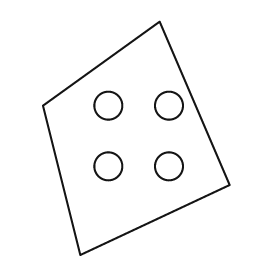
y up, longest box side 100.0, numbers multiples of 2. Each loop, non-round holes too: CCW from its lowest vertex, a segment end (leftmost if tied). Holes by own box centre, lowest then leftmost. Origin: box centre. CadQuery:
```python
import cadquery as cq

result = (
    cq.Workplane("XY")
    .moveTo(-24.0, -50.0)
    .lineTo(40.0, -20.0)
    .lineTo(10.0, 50.0)
    .lineTo(-40.0, 14.0)
    .close()
    .moveTo(-12.0, -12.0)
    .circle(6.0)
    .moveTo(14.0, -12.0)
    .circle(6.0)
    .moveTo(-12.0, 14.0)
    .circle(6.0)
    .moveTo(14.0, 14.0)
    .circle(6.0)
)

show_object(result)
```